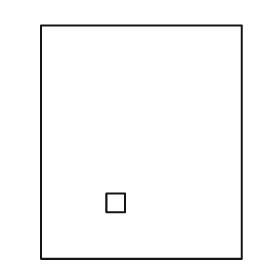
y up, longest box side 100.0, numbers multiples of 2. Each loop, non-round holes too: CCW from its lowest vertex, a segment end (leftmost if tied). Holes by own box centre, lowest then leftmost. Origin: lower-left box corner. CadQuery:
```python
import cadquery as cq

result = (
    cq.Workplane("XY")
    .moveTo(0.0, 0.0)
    .lineTo(86.0, 0.0)
    .lineTo(86.0, 100.0)
    .lineTo(0.0, 100.0)
    .close()
    .moveTo(28.0, 20.0)
    .lineTo(36.0, 20.0)
    .lineTo(36.0, 28.0)
    .lineTo(28.0, 28.0)
    .close()
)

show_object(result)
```